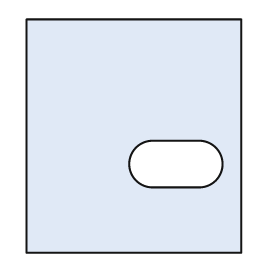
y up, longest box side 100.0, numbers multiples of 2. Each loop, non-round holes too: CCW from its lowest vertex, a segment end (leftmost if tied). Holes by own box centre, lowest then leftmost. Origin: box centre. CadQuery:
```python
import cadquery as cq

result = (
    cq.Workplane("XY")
    .moveTo(-46.0, -50.0)
    .lineTo(46.0, -50.0)
    .lineTo(46.0, 50.0)
    .lineTo(-46.0, 50.0)
    .close()
    .moveTo(8.0, -22.0)
    .lineTo(28.0, -22.0)
    .threePointArc((38.0, -12.0), (28.0, -2.0))
    .lineTo(8.0, -2.0)
    .threePointArc((-2.0, -12.0), (8.0, -22.0))
    .close()
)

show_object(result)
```